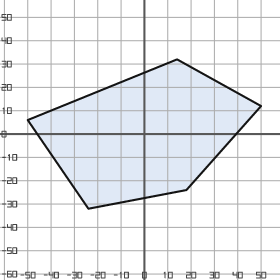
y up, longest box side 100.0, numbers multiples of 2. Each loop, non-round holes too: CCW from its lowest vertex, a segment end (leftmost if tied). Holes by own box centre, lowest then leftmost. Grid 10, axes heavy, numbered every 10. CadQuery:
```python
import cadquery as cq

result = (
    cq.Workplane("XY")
    .moveTo(-24.0, -32.0)
    .lineTo(18.0, -24.0)
    .lineTo(50.0, 12.0)
    .lineTo(14.0, 32.0)
    .lineTo(-50.0, 6.0)
    .close()
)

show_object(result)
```